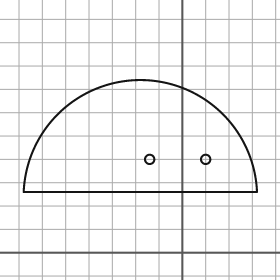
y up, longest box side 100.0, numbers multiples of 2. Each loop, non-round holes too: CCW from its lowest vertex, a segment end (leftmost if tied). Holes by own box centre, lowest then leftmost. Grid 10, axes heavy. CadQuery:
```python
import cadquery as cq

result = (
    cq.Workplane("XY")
    .moveTo(-68.0, 26.0)
    .lineTo(32.0, 26.0)
    .threePointArc((-18.0, 74.0), (-68.0, 26.0))
    .close()
    .moveTo(-14.0, 40.0)
    .circle(2.0)
    .moveTo(10.0, 40.0)
    .circle(2.0)
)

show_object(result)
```